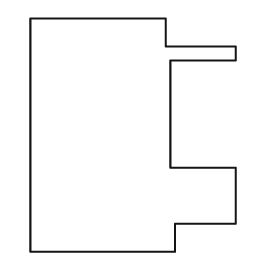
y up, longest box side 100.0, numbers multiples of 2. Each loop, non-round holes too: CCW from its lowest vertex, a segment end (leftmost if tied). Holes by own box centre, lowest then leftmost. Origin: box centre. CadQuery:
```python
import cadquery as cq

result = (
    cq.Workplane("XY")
    .moveTo(-44.0, -50.0)
    .lineTo(18.0, -50.0)
    .lineTo(18.0, -38.0)
    .lineTo(44.0, -38.0)
    .lineTo(44.0, -14.0)
    .lineTo(16.0, -14.0)
    .lineTo(16.0, 32.0)
    .lineTo(44.0, 32.0)
    .lineTo(44.0, 38.0)
    .lineTo(14.0, 38.0)
    .lineTo(14.0, 50.0)
    .lineTo(-44.0, 50.0)
    .close()
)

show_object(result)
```